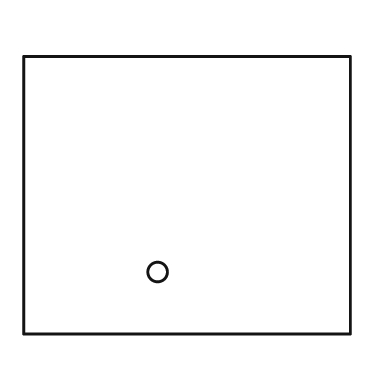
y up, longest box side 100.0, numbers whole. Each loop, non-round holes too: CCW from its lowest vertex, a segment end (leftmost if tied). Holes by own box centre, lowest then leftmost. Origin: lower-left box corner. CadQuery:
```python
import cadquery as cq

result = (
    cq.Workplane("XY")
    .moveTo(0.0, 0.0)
    .lineTo(100.0, 0.0)
    .lineTo(100.0, 85.0)
    .lineTo(0.0, 85.0)
    .close()
    .moveTo(41.0, 19.0)
    .circle(3.0)
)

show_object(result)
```